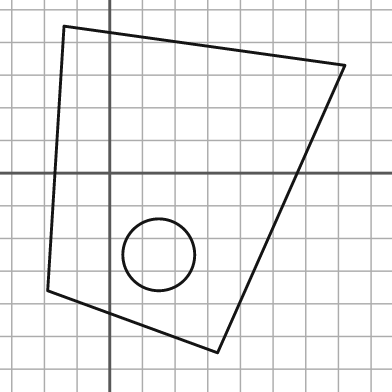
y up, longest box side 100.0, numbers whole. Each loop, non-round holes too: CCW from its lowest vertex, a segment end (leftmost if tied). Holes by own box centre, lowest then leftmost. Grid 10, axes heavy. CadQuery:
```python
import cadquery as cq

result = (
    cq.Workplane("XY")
    .moveTo(33.0, -55.0)
    .lineTo(72.0, 33.0)
    .lineTo(-14.0, 45.0)
    .lineTo(-19.0, -36.0)
    .close()
    .moveTo(15.0, -25.0)
    .circle(11.0)
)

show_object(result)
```